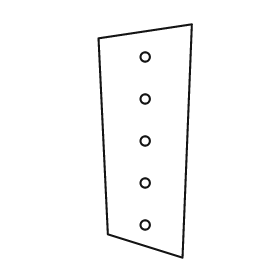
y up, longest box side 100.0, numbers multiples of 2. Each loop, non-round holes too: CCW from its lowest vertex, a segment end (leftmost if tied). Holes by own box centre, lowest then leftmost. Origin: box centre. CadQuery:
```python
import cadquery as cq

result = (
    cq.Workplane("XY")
    .moveTo(16.0, -50.0)
    .lineTo(20.0, 50.0)
    .lineTo(-20.0, 44.0)
    .lineTo(-16.0, -40.0)
    .close()
    .moveTo(0.0, -36.0)
    .circle(2.0)
    .moveTo(0.0, -18.0)
    .circle(2.0)
    .moveTo(0.0, 0.0)
    .circle(2.0)
    .moveTo(0.0, 18.0)
    .circle(2.0)
    .moveTo(0.0, 36.0)
    .circle(2.0)
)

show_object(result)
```